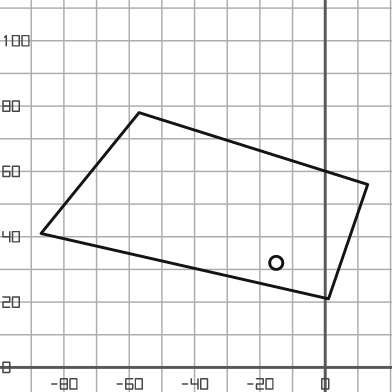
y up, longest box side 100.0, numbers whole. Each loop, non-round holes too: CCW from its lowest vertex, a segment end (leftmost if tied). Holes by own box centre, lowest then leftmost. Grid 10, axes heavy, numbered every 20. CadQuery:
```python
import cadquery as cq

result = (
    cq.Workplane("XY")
    .moveTo(1.0, 21.0)
    .lineTo(13.0, 56.0)
    .lineTo(-57.0, 78.0)
    .lineTo(-87.0, 41.0)
    .close()
    .moveTo(-15.0, 32.0)
    .circle(2.0)
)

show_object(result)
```